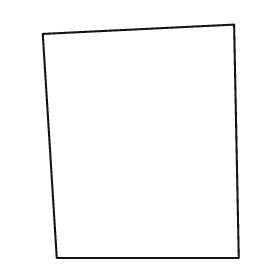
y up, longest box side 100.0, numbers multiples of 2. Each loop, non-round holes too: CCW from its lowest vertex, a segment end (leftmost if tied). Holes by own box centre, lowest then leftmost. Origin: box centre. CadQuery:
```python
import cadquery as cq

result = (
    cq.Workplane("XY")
    .moveTo(-36.0, -50.0)
    .lineTo(42.0, -50.0)
    .lineTo(40.0, 50.0)
    .lineTo(-42.0, 46.0)
    .close()
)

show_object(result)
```